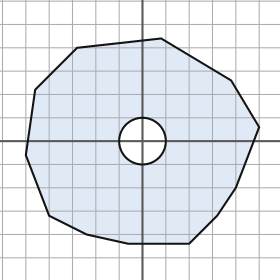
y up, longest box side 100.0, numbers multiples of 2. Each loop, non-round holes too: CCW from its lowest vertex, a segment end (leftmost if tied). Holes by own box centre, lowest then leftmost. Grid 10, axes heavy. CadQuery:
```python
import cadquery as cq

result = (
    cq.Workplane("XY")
    .moveTo(-6.0, -44.0)
    .lineTo(20.0, -44.0)
    .lineTo(32.0, -32.0)
    .lineTo(40.0, -20.0)
    .lineTo(50.0, 6.0)
    .lineTo(38.0, 26.0)
    .lineTo(8.0, 44.0)
    .lineTo(-28.0, 40.0)
    .lineTo(-46.0, 22.0)
    .lineTo(-50.0, -6.0)
    .lineTo(-40.0, -32.0)
    .lineTo(-24.0, -40.0)
    .close()
    .moveTo(0.0, 0.0)
    .circle(10.0)
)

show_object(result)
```